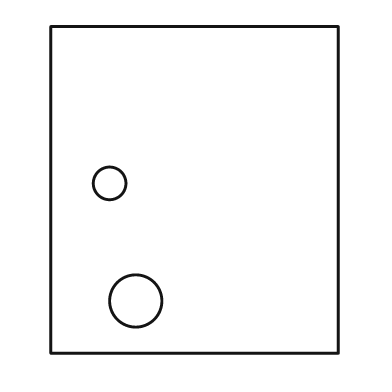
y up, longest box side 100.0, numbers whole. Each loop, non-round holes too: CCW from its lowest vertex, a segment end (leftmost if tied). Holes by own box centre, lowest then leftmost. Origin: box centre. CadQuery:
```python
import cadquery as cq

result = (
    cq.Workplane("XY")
    .moveTo(-44.0, -50.0)
    .lineTo(44.0, -50.0)
    .lineTo(44.0, 50.0)
    .lineTo(-44.0, 50.0)
    .close()
    .moveTo(-18.0, -34.0)
    .circle(8.0)
    .moveTo(-26.0, 2.0)
    .circle(5.0)
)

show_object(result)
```